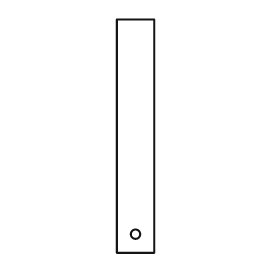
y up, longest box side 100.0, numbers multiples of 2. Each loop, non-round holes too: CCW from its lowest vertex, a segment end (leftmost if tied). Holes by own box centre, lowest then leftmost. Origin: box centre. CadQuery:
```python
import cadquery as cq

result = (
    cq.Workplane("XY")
    .moveTo(-8.0, -50.0)
    .lineTo(8.0, -50.0)
    .lineTo(8.0, 50.0)
    .lineTo(-8.0, 50.0)
    .close()
    .moveTo(0.0, -42.0)
    .circle(2.0)
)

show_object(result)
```